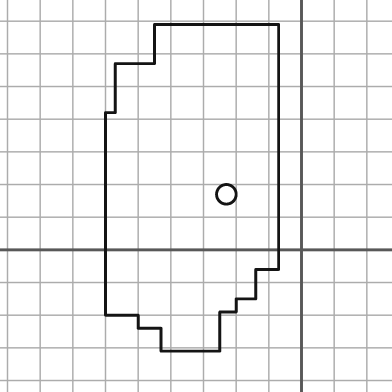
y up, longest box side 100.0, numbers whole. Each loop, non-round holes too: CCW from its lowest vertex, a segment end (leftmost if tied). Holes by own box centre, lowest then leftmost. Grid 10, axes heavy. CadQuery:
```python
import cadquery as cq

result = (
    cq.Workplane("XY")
    .moveTo(-43.0, -31.0)
    .lineTo(-25.0, -31.0)
    .lineTo(-25.0, -19.0)
    .lineTo(-20.0, -19.0)
    .lineTo(-20.0, -15.0)
    .lineTo(-14.0, -15.0)
    .lineTo(-14.0, -6.0)
    .lineTo(-7.0, -6.0)
    .lineTo(-7.0, 69.0)
    .lineTo(-45.0, 69.0)
    .lineTo(-45.0, 57.0)
    .lineTo(-57.0, 57.0)
    .lineTo(-57.0, 42.0)
    .lineTo(-60.0, 42.0)
    .lineTo(-60.0, -20.0)
    .lineTo(-50.0, -20.0)
    .lineTo(-50.0, -24.0)
    .lineTo(-43.0, -24.0)
    .close()
    .moveTo(-23.0, 17.0)
    .circle(3.0)
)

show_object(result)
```